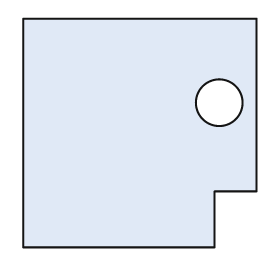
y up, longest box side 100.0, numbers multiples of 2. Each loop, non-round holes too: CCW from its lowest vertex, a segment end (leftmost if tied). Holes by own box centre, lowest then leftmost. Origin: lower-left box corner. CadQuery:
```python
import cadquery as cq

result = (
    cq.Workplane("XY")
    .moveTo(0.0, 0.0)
    .lineTo(82.0, 0.0)
    .lineTo(82.0, 24.0)
    .lineTo(100.0, 24.0)
    .lineTo(100.0, 98.0)
    .lineTo(0.0, 98.0)
    .close()
    .moveTo(84.0, 62.0)
    .circle(10.0)
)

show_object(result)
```